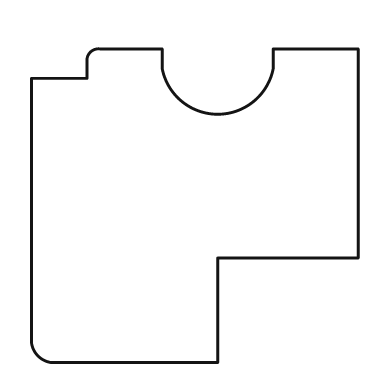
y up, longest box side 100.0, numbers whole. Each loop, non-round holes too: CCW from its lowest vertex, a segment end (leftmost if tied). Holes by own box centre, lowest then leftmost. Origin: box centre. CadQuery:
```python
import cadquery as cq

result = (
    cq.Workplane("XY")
    .moveTo(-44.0, -48.0)
    .lineTo(7.0, -48.0)
    .lineTo(7.0, -16.0)
    .lineTo(50.0, -16.0)
    .lineTo(50.0, 48.0)
    .lineTo(24.0, 48.0)
    .lineTo(24.0, 42.0)
    .threePointArc((7.0, 28.0), (-10.0, 42.0))
    .lineTo(-10.0, 48.0)
    .lineTo(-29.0, 48.0)
    .threePointArc((-32.0, 47.0), (-33.0, 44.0))
    .lineTo(-33.0, 39.0)
    .lineTo(-50.0, 39.0)
    .lineTo(-50.0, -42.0)
    .threePointArc((-48.0, -46.0), (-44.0, -48.0))
    .close()
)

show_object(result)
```